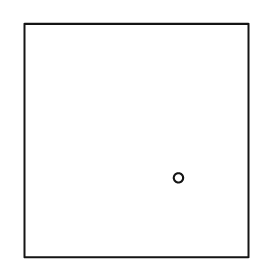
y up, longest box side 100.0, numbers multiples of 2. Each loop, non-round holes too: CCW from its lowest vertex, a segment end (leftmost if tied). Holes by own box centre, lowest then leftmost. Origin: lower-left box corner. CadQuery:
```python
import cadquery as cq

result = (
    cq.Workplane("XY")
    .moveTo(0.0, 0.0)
    .lineTo(96.0, 0.0)
    .lineTo(96.0, 100.0)
    .lineTo(0.0, 100.0)
    .close()
    .moveTo(66.0, 34.0)
    .circle(2.0)
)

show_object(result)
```